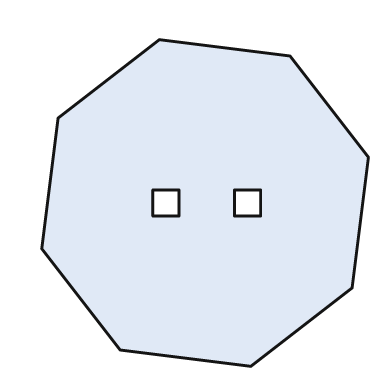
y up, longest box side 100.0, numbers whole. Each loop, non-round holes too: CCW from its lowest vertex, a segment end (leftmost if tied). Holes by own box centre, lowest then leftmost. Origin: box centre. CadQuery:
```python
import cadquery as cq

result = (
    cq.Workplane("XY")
    .moveTo(14.0, -50.0)
    .lineTo(45.0, -26.0)
    .lineTo(50.0, 14.0)
    .lineTo(26.0, 45.0)
    .lineTo(-14.0, 50.0)
    .lineTo(-45.0, 26.0)
    .lineTo(-50.0, -14.0)
    .lineTo(-26.0, -45.0)
    .close()
    .moveTo(-16.0, -4.0)
    .lineTo(-8.0, -4.0)
    .lineTo(-8.0, 4.0)
    .lineTo(-16.0, 4.0)
    .close()
    .moveTo(9.0, -4.0)
    .lineTo(17.0, -4.0)
    .lineTo(17.0, 4.0)
    .lineTo(9.0, 4.0)
    .close()
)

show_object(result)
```